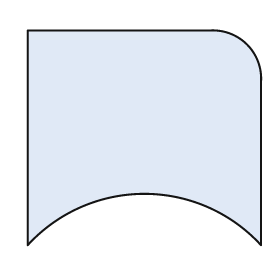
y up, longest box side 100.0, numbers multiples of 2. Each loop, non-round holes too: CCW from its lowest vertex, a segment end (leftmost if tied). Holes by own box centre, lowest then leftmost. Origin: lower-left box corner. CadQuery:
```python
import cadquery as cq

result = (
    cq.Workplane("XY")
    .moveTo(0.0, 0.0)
    .threePointArc((50.0, 22.0), (100.0, 0.0))
    .lineTo(100.0, 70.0)
    .threePointArc((94.0, 86.0), (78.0, 92.0))
    .lineTo(0.0, 92.0)
    .close()
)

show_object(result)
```